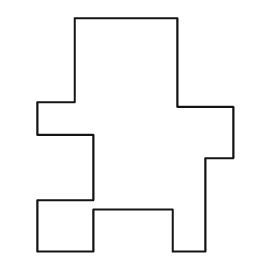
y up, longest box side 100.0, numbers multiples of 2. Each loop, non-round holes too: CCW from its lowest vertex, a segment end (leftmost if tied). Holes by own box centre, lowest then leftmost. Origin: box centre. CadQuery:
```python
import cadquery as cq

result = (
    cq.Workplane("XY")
    .moveTo(-42.0, -50.0)
    .lineTo(-18.0, -50.0)
    .lineTo(-18.0, -32.0)
    .lineTo(16.0, -32.0)
    .lineTo(16.0, -50.0)
    .lineTo(30.0, -50.0)
    .lineTo(30.0, -10.0)
    .lineTo(42.0, -10.0)
    .lineTo(42.0, 12.0)
    .lineTo(18.0, 12.0)
    .lineTo(18.0, 50.0)
    .lineTo(-26.0, 50.0)
    .lineTo(-26.0, 14.0)
    .lineTo(-42.0, 14.0)
    .lineTo(-42.0, 0.0)
    .lineTo(-18.0, 0.0)
    .lineTo(-18.0, -28.0)
    .lineTo(-42.0, -28.0)
    .close()
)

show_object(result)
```